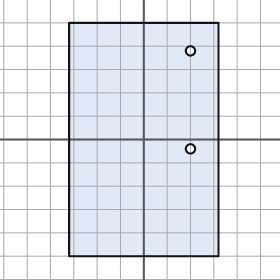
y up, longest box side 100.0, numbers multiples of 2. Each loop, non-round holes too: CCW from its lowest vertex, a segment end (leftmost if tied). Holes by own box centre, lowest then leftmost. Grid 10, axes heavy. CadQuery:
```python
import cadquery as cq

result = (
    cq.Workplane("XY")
    .moveTo(-32.0, -50.0)
    .lineTo(32.0, -50.0)
    .lineTo(32.0, 50.0)
    .lineTo(-32.0, 50.0)
    .close()
    .moveTo(20.0, -4.0)
    .circle(2.0)
    .moveTo(20.0, 38.0)
    .circle(2.0)
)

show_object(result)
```